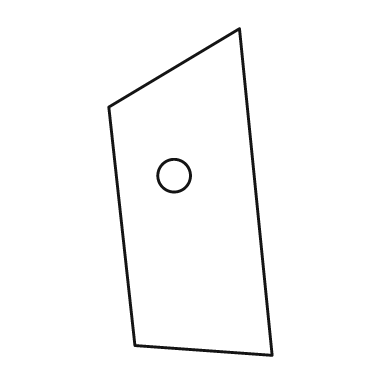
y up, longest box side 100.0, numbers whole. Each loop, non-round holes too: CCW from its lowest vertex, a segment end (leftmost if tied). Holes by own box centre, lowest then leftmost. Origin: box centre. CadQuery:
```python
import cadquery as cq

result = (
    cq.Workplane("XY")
    .moveTo(25.0, -50.0)
    .lineTo(15.0, 50.0)
    .lineTo(-25.0, 26.0)
    .lineTo(-17.0, -47.0)
    .close()
    .moveTo(-5.0, 5.0)
    .circle(5.0)
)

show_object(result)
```